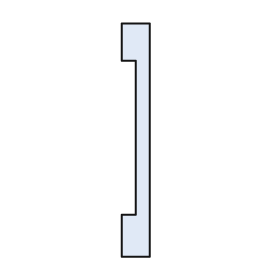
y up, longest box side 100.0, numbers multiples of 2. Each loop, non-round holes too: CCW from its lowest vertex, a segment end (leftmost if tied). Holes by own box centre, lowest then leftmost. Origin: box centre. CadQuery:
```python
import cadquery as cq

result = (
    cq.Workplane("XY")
    .moveTo(-6.0, -50.0)
    .lineTo(6.0, -50.0)
    .lineTo(6.0, 50.0)
    .lineTo(-6.0, 50.0)
    .lineTo(-6.0, 34.0)
    .lineTo(0.0, 34.0)
    .lineTo(0.0, -32.0)
    .lineTo(-6.0, -32.0)
    .close()
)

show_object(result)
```